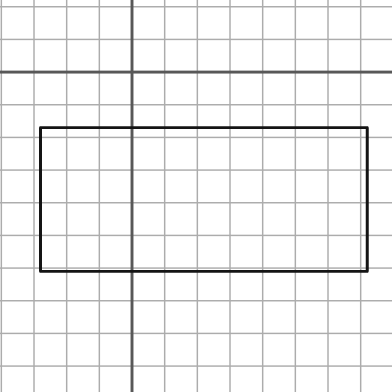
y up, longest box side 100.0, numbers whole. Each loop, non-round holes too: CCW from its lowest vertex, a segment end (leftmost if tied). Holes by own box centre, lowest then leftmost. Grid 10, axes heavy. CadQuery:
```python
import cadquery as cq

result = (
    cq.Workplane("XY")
    .moveTo(-28.0, -61.0)
    .lineTo(72.0, -61.0)
    .lineTo(72.0, -17.0)
    .lineTo(-28.0, -17.0)
    .close()
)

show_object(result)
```